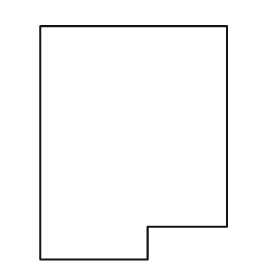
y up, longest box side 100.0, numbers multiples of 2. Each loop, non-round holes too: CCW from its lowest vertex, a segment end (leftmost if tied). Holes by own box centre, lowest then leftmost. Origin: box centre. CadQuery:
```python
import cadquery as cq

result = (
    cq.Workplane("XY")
    .moveTo(-40.0, -50.0)
    .lineTo(6.0, -50.0)
    .lineTo(6.0, -36.0)
    .lineTo(40.0, -36.0)
    .lineTo(40.0, 50.0)
    .lineTo(-40.0, 50.0)
    .close()
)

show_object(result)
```